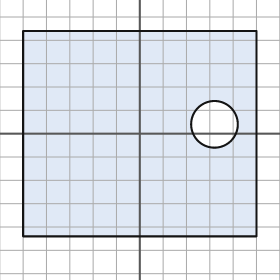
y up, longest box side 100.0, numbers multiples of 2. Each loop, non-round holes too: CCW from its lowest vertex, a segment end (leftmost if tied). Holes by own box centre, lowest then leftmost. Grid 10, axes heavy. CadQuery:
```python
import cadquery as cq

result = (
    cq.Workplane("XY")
    .moveTo(-50.0, -44.0)
    .lineTo(50.0, -44.0)
    .lineTo(50.0, 44.0)
    .lineTo(-50.0, 44.0)
    .close()
    .moveTo(32.0, 4.0)
    .circle(10.0)
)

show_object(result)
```